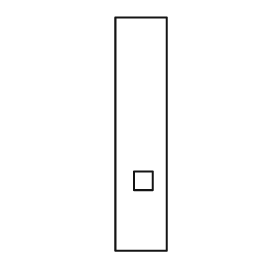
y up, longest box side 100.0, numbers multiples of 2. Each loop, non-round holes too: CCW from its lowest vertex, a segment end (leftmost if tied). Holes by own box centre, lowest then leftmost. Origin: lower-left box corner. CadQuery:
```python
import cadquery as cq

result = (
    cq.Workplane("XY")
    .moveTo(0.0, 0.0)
    .lineTo(22.0, 0.0)
    .lineTo(22.0, 100.0)
    .lineTo(0.0, 100.0)
    .close()
    .moveTo(8.0, 26.0)
    .lineTo(16.0, 26.0)
    .lineTo(16.0, 34.0)
    .lineTo(8.0, 34.0)
    .close()
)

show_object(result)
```